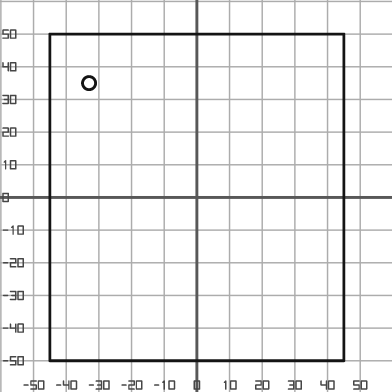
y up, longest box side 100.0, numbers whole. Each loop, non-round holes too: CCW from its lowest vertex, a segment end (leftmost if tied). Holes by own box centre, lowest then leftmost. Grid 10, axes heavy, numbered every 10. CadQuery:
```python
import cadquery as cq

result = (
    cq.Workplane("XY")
    .moveTo(-45.0, -50.0)
    .lineTo(45.0, -50.0)
    .lineTo(45.0, 50.0)
    .lineTo(-45.0, 50.0)
    .close()
    .moveTo(-33.0, 35.0)
    .circle(2.0)
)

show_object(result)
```